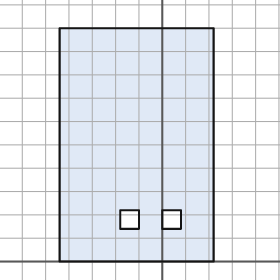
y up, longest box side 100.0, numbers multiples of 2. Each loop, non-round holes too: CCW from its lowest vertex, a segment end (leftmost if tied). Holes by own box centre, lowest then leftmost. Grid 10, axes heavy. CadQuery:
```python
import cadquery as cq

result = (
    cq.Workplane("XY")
    .moveTo(-44.0, 0.0)
    .lineTo(22.0, 0.0)
    .lineTo(22.0, 100.0)
    .lineTo(-44.0, 100.0)
    .close()
    .moveTo(-18.0, 14.0)
    .lineTo(-10.0, 14.0)
    .lineTo(-10.0, 22.0)
    .lineTo(-18.0, 22.0)
    .close()
    .moveTo(0.0, 14.0)
    .lineTo(8.0, 14.0)
    .lineTo(8.0, 22.0)
    .lineTo(0.0, 22.0)
    .close()
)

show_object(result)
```